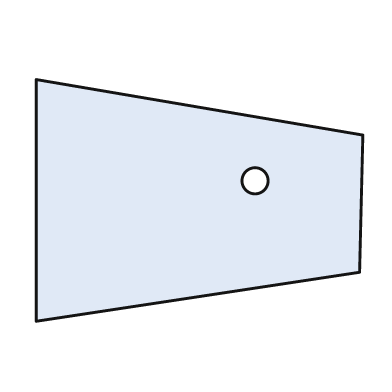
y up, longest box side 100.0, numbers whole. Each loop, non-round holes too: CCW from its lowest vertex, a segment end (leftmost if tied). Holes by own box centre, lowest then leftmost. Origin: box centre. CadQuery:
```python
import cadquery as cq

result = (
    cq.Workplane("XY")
    .moveTo(-50.0, -37.0)
    .lineTo(49.0, -22.0)
    .lineTo(50.0, 20.0)
    .lineTo(-50.0, 37.0)
    .close()
    .moveTo(17.0, 6.0)
    .circle(4.0)
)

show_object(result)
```